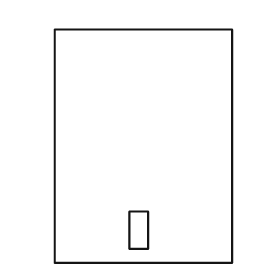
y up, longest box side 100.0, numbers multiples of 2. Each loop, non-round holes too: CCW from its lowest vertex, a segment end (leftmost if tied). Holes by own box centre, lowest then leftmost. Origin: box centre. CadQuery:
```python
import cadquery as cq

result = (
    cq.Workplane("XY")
    .moveTo(-38.0, -50.0)
    .lineTo(38.0, -50.0)
    .lineTo(38.0, 50.0)
    .lineTo(-38.0, 50.0)
    .close()
    .moveTo(-6.0, -44.0)
    .lineTo(2.0, -44.0)
    .lineTo(2.0, -28.0)
    .lineTo(-6.0, -28.0)
    .close()
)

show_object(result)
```